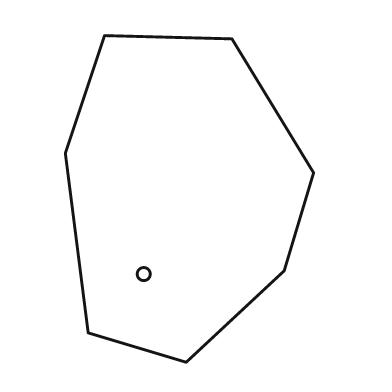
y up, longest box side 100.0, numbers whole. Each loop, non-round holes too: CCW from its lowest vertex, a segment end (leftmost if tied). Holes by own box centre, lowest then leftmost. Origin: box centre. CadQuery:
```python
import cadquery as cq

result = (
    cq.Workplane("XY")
    .moveTo(-1.0, -50.0)
    .lineTo(29.0, -22.0)
    .lineTo(38.0, 8.0)
    .lineTo(13.0, 49.0)
    .lineTo(-26.0, 50.0)
    .lineTo(-38.0, 14.0)
    .lineTo(-31.0, -41.0)
    .close()
    .moveTo(-14.0, -23.0)
    .circle(2.0)
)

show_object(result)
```